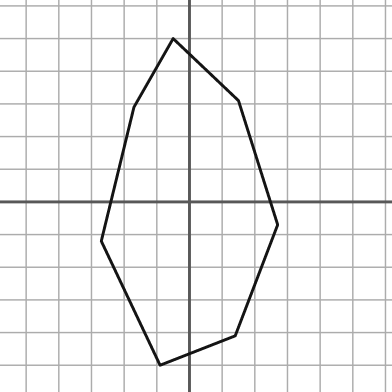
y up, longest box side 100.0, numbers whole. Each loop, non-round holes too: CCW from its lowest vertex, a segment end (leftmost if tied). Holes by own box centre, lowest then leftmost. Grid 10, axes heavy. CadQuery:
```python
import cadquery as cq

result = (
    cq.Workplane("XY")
    .moveTo(-9.0, -50.0)
    .lineTo(14.0, -41.0)
    .lineTo(27.0, -7.0)
    .lineTo(15.0, 31.0)
    .lineTo(-5.0, 50.0)
    .lineTo(-17.0, 29.0)
    .lineTo(-27.0, -12.0)
    .close()
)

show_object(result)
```